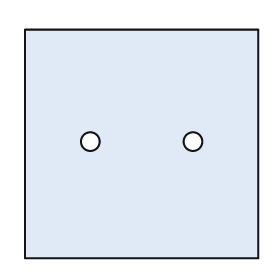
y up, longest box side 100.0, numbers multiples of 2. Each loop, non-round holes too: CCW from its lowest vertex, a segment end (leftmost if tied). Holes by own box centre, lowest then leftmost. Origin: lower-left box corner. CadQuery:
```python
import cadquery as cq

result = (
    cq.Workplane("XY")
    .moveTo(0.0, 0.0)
    .lineTo(100.0, 0.0)
    .lineTo(100.0, 98.0)
    .lineTo(0.0, 98.0)
    .close()
    .moveTo(28.0, 50.0)
    .circle(4.0)
    .moveTo(72.0, 50.0)
    .circle(4.0)
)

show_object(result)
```